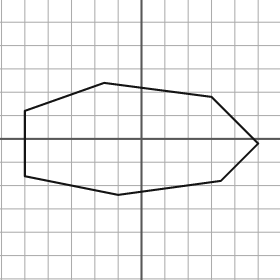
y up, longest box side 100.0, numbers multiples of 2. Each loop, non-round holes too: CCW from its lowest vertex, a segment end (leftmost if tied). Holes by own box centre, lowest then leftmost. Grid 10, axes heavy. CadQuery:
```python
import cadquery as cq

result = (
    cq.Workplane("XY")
    .moveTo(-10.0, -24.0)
    .lineTo(34.0, -18.0)
    .lineTo(50.0, -2.0)
    .lineTo(30.0, 18.0)
    .lineTo(-16.0, 24.0)
    .lineTo(-50.0, 12.0)
    .lineTo(-50.0, -16.0)
    .close()
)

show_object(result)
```